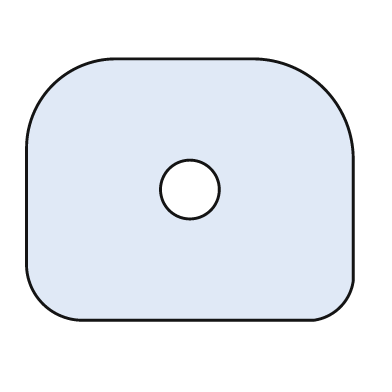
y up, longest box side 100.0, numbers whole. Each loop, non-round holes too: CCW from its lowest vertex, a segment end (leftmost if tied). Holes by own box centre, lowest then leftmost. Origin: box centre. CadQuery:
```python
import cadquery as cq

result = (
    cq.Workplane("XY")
    .moveTo(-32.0, -40.0)
    .lineTo(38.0, -40.0)
    .threePointArc((46.0, -36.0), (50.0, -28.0))
    .lineTo(50.0, 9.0)
    .threePointArc((41.0, 31.0), (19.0, 40.0))
    .lineTo(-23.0, 40.0)
    .threePointArc((-42.0, 32.0), (-50.0, 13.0))
    .lineTo(-50.0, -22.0)
    .threePointArc((-45.0, -35.0), (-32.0, -40.0))
    .close()
    .moveTo(0.0, 0.0)
    .circle(9.0)
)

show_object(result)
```